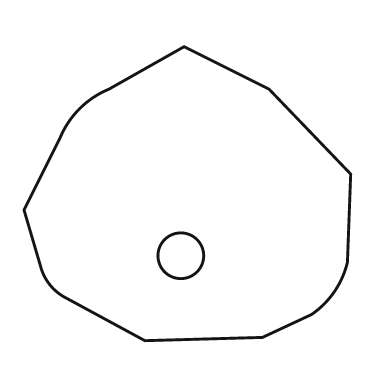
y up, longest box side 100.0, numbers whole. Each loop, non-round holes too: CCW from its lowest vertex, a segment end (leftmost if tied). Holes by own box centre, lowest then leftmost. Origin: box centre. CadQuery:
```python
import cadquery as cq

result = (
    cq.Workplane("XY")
    .moveTo(-13.0, -45.0)
    .lineTo(23.0, -44.0)
    .lineTo(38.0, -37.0)
    .threePointArc((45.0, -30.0), (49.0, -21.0))
    .lineTo(50.0, 6.0)
    .lineTo(25.0, 32.0)
    .lineTo(-1.0, 45.0)
    .lineTo(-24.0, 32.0)
    .threePointArc((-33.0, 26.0), (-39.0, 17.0))
    .lineTo(-50.0, -5.0)
    .lineTo(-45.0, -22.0)
    .threePointArc((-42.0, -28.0), (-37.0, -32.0))
    .close()
    .moveTo(-2.0, -19.0)
    .circle(7.0)
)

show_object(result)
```